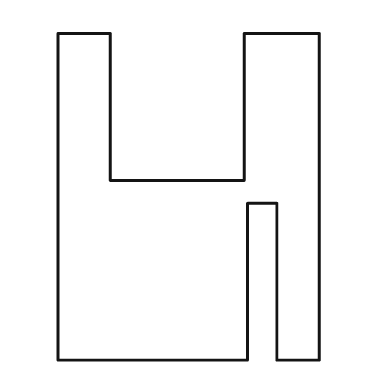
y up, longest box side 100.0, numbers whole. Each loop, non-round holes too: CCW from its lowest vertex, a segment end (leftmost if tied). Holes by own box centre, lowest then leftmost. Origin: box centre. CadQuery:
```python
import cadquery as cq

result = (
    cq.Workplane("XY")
    .moveTo(-40.0, -50.0)
    .lineTo(18.0, -50.0)
    .lineTo(18.0, -2.0)
    .lineTo(27.0, -2.0)
    .lineTo(27.0, -50.0)
    .lineTo(40.0, -50.0)
    .lineTo(40.0, 50.0)
    .lineTo(17.0, 50.0)
    .lineTo(17.0, 5.0)
    .lineTo(-24.0, 5.0)
    .lineTo(-24.0, 50.0)
    .lineTo(-40.0, 50.0)
    .close()
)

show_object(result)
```